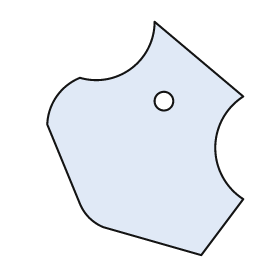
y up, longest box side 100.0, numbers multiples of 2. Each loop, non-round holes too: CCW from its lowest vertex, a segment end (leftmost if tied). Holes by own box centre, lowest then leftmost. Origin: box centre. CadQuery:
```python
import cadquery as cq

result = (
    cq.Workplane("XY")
    .moveTo(24.0, -50.0)
    .lineTo(42.0, -26.0)
    .threePointArc((30.0, -4.0), (42.0, 18.0))
    .lineTo(4.0, 50.0)
    .threePointArc((-6.0, 30.0), (-28.0, 26.0))
    .threePointArc((-38.0, 18.0), (-42.0, 6.0))
    .lineTo(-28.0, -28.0)
    .threePointArc((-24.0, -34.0), (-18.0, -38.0))
    .close()
    .moveTo(8.0, 16.0)
    .circle(4.0)
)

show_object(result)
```